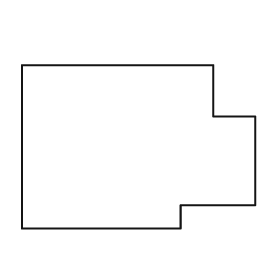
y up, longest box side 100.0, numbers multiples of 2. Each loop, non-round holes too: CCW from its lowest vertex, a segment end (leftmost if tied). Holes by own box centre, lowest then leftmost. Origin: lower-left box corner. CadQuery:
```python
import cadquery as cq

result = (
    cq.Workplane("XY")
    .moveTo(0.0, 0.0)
    .lineTo(68.0, 0.0)
    .lineTo(68.0, 10.0)
    .lineTo(100.0, 10.0)
    .lineTo(100.0, 48.0)
    .lineTo(82.0, 48.0)
    .lineTo(82.0, 70.0)
    .lineTo(0.0, 70.0)
    .close()
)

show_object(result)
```